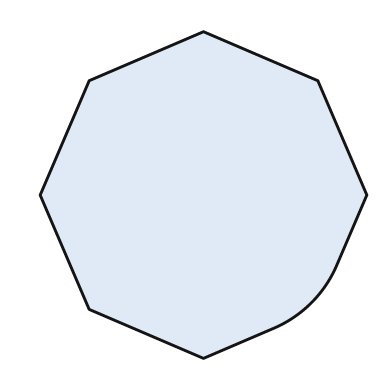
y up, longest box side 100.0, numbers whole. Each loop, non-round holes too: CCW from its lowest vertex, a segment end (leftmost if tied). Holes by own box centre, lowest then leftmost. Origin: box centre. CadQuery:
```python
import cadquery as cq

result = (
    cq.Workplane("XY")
    .moveTo(0.0, -50.0)
    .lineTo(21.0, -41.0)
    .threePointArc((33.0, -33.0), (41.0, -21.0))
    .lineTo(50.0, 0.0)
    .lineTo(35.0, 35.0)
    .lineTo(0.0, 50.0)
    .lineTo(-35.0, 35.0)
    .lineTo(-50.0, 0.0)
    .lineTo(-35.0, -35.0)
    .close()
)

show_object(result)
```